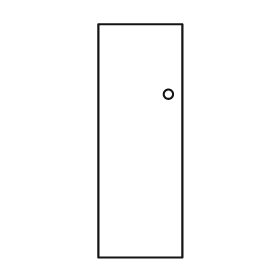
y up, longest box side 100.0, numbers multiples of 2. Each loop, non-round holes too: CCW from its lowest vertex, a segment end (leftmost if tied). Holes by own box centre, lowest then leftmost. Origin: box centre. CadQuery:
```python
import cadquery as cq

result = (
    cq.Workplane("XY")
    .moveTo(-18.0, -50.0)
    .lineTo(18.0, -50.0)
    .lineTo(18.0, 50.0)
    .lineTo(-18.0, 50.0)
    .close()
    .moveTo(12.0, 20.0)
    .circle(2.0)
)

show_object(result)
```